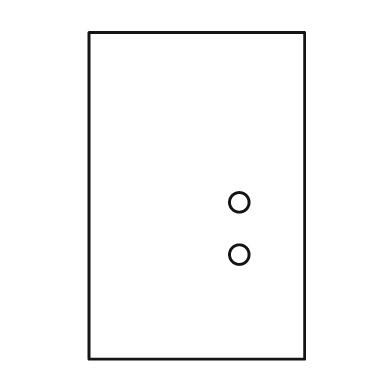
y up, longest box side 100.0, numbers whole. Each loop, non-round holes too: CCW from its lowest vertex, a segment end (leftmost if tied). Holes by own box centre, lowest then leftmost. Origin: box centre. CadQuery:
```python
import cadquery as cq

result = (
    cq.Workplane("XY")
    .moveTo(-33.0, -50.0)
    .lineTo(33.0, -50.0)
    .lineTo(33.0, 50.0)
    .lineTo(-33.0, 50.0)
    .close()
    .moveTo(13.0, -18.0)
    .circle(3.0)
    .moveTo(13.0, -2.0)
    .circle(3.0)
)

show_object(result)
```